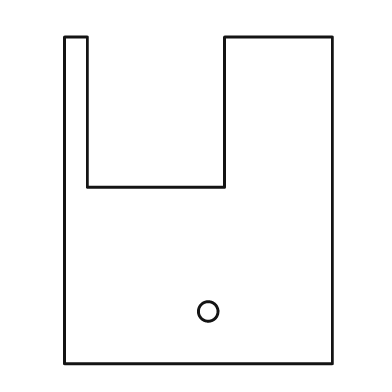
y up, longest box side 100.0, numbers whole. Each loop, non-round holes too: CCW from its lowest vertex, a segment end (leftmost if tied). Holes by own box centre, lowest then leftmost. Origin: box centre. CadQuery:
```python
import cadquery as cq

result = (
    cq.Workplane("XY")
    .moveTo(-41.0, -50.0)
    .lineTo(41.0, -50.0)
    .lineTo(41.0, 50.0)
    .lineTo(8.0, 50.0)
    .lineTo(8.0, 4.0)
    .lineTo(-34.0, 4.0)
    .lineTo(-34.0, 50.0)
    .lineTo(-41.0, 50.0)
    .close()
    .moveTo(3.0, -34.0)
    .circle(3.0)
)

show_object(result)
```